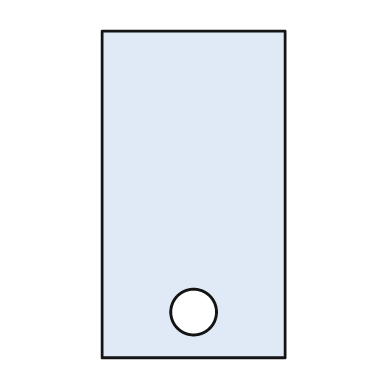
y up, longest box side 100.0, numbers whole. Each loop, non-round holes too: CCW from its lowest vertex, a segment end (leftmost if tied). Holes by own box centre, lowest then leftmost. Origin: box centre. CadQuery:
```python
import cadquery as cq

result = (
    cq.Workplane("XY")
    .moveTo(-28.0, -50.0)
    .lineTo(28.0, -50.0)
    .lineTo(28.0, 50.0)
    .lineTo(-28.0, 50.0)
    .close()
    .moveTo(0.0, -36.0)
    .circle(7.0)
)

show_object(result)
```